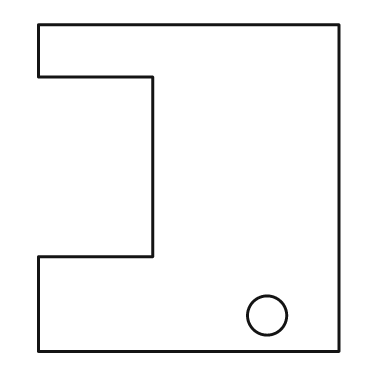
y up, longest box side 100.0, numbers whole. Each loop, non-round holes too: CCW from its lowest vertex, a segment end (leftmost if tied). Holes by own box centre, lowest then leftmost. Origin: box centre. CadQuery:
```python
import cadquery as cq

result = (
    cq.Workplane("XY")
    .moveTo(-46.0, -50.0)
    .lineTo(46.0, -50.0)
    .lineTo(46.0, 50.0)
    .lineTo(-46.0, 50.0)
    .lineTo(-46.0, 34.0)
    .lineTo(-11.0, 34.0)
    .lineTo(-11.0, -21.0)
    .lineTo(-46.0, -21.0)
    .close()
    .moveTo(24.0, -39.0)
    .circle(6.0)
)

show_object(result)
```